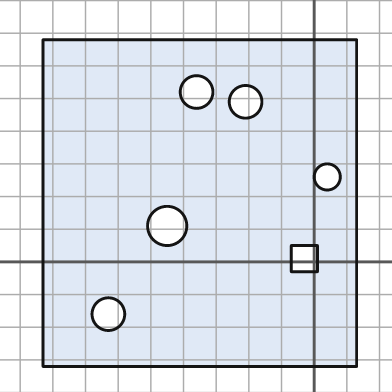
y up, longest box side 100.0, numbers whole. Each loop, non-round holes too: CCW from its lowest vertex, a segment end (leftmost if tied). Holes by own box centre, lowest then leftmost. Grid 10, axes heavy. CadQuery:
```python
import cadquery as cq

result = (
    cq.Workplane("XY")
    .moveTo(-83.0, -32.0)
    .lineTo(13.0, -32.0)
    .lineTo(13.0, 68.0)
    .lineTo(-83.0, 68.0)
    .close()
    .moveTo(-63.0, -16.0)
    .circle(5.0)
    .moveTo(-7.0, -3.0)
    .lineTo(1.0, -3.0)
    .lineTo(1.0, 5.0)
    .lineTo(-7.0, 5.0)
    .close()
    .moveTo(-45.0, 11.0)
    .circle(6.0)
    .moveTo(4.0, 26.0)
    .circle(4.0)
    .moveTo(-21.0, 49.0)
    .circle(5.0)
    .moveTo(-36.0, 52.0)
    .circle(5.0)
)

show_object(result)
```